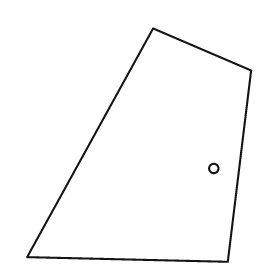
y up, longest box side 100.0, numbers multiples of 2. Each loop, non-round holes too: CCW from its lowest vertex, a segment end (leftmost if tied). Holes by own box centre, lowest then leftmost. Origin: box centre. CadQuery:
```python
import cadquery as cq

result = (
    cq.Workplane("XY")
    .moveTo(38.0, -50.0)
    .lineTo(48.0, 32.0)
    .lineTo(6.0, 50.0)
    .lineTo(-48.0, -48.0)
    .close()
    .moveTo(32.0, -10.0)
    .circle(2.0)
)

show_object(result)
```